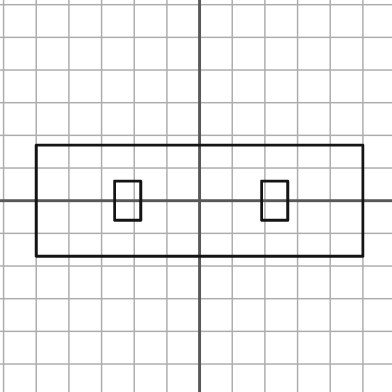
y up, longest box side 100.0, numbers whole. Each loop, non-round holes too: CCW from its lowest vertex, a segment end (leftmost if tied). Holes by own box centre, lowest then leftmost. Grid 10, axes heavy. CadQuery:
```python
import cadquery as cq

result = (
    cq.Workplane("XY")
    .moveTo(-50.0, -17.0)
    .lineTo(50.0, -17.0)
    .lineTo(50.0, 17.0)
    .lineTo(-50.0, 17.0)
    .close()
    .moveTo(-26.0, -6.0)
    .lineTo(-18.0, -6.0)
    .lineTo(-18.0, 6.0)
    .lineTo(-26.0, 6.0)
    .close()
    .moveTo(19.0, -6.0)
    .lineTo(27.0, -6.0)
    .lineTo(27.0, 6.0)
    .lineTo(19.0, 6.0)
    .close()
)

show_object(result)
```